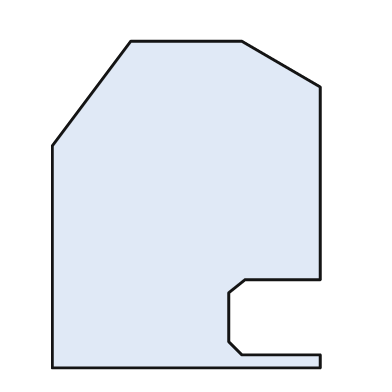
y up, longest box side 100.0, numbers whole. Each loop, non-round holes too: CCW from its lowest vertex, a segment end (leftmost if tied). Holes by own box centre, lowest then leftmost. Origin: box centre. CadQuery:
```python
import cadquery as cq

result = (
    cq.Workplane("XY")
    .moveTo(-41.0, -50.0)
    .lineTo(41.0, -50.0)
    .lineTo(41.0, -46.0)
    .lineTo(17.0, -46.0)
    .lineTo(13.0, -42.0)
    .lineTo(13.0, -27.0)
    .lineTo(18.0, -23.0)
    .lineTo(41.0, -23.0)
    .lineTo(41.0, 36.0)
    .lineTo(17.0, 50.0)
    .lineTo(-17.0, 50.0)
    .lineTo(-41.0, 18.0)
    .close()
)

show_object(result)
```